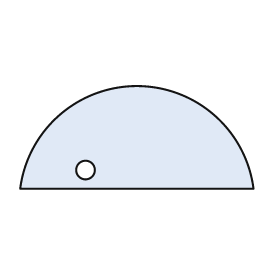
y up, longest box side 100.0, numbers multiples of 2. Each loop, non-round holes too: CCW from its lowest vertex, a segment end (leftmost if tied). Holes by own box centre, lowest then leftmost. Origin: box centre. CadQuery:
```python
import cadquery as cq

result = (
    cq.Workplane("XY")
    .moveTo(-50.0, -22.0)
    .lineTo(50.0, -22.0)
    .threePointArc((0.0, 22.0), (-50.0, -22.0))
    .close()
    .moveTo(-22.0, -14.0)
    .circle(4.0)
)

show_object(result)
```